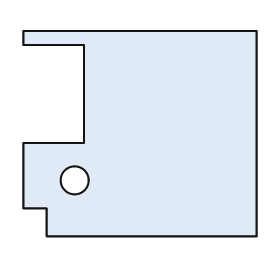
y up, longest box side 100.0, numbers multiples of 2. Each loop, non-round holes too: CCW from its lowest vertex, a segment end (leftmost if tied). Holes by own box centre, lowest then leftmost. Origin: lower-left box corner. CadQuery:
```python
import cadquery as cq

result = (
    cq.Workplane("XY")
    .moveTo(10.0, 0.0)
    .lineTo(100.0, 0.0)
    .lineTo(100.0, 88.0)
    .lineTo(0.0, 88.0)
    .lineTo(0.0, 82.0)
    .lineTo(26.0, 82.0)
    .lineTo(26.0, 40.0)
    .lineTo(0.0, 40.0)
    .lineTo(0.0, 12.0)
    .lineTo(10.0, 12.0)
    .close()
    .moveTo(22.0, 24.0)
    .circle(6.0)
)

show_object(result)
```